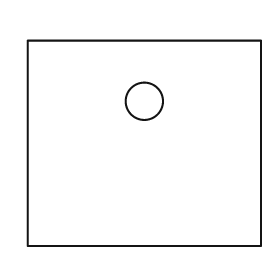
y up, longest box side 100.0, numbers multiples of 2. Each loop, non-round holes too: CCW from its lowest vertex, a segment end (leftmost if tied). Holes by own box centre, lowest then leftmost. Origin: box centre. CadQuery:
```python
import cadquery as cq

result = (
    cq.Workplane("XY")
    .moveTo(-50.0, -44.0)
    .lineTo(50.0, -44.0)
    .lineTo(50.0, 44.0)
    .lineTo(-50.0, 44.0)
    .close()
    .moveTo(0.0, 18.0)
    .circle(8.0)
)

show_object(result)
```